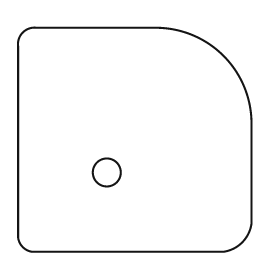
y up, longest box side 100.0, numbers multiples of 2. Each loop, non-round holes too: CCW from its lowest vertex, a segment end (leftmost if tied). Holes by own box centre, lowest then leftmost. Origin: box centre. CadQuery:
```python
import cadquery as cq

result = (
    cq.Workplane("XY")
    .moveTo(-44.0, -48.0)
    .lineTo(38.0, -48.0)
    .threePointArc((46.0, -44.0), (50.0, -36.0))
    .lineTo(50.0, 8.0)
    .threePointArc((38.0, 36.0), (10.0, 48.0))
    .lineTo(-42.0, 48.0)
    .threePointArc((-48.0, 46.0), (-50.0, 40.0))
    .lineTo(-50.0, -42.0)
    .threePointArc((-48.0, -46.0), (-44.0, -48.0))
    .close()
    .moveTo(-12.0, -14.0)
    .circle(6.0)
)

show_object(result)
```